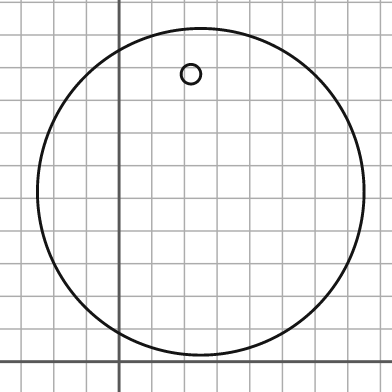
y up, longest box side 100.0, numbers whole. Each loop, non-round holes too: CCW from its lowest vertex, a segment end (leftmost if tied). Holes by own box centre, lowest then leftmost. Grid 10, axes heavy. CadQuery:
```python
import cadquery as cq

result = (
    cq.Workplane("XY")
    .moveTo(25.0, 52.0)
    .circle(50.0)
    .moveTo(22.0, 88.0)
    .circle(3.0)
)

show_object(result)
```